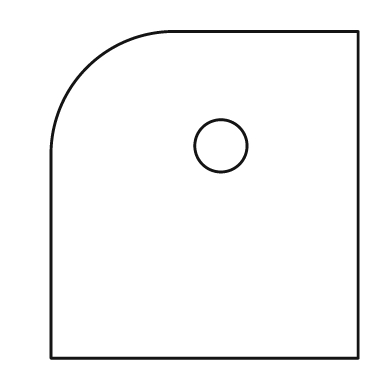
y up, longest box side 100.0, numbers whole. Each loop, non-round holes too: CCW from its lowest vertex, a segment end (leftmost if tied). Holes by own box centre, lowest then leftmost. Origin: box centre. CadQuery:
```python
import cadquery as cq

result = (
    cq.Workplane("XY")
    .moveTo(-47.0, -50.0)
    .lineTo(47.0, -50.0)
    .lineTo(47.0, 50.0)
    .lineTo(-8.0, 50.0)
    .threePointArc((-36.0, 39.0), (-47.0, 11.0))
    .close()
    .moveTo(5.0, 15.0)
    .circle(8.0)
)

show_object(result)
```